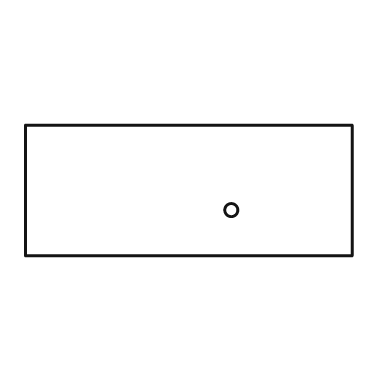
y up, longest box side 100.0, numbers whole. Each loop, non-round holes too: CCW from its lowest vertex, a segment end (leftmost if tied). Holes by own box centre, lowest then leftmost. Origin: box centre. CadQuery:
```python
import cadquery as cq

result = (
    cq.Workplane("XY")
    .moveTo(-50.0, -20.0)
    .lineTo(50.0, -20.0)
    .lineTo(50.0, 20.0)
    .lineTo(-50.0, 20.0)
    .close()
    .moveTo(13.0, -6.0)
    .circle(2.0)
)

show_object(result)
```